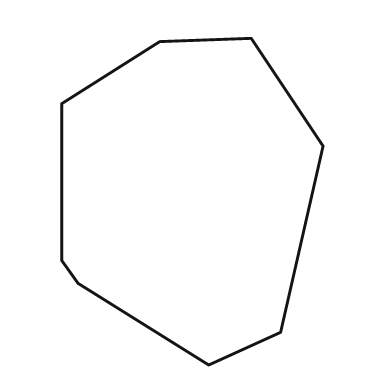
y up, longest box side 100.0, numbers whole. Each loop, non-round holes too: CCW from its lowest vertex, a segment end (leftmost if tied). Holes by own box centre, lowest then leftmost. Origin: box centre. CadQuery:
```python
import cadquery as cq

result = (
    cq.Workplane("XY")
    .moveTo(5.0, -50.0)
    .lineTo(27.0, -40.0)
    .lineTo(40.0, 17.0)
    .lineTo(18.0, 50.0)
    .lineTo(-10.0, 49.0)
    .lineTo(-40.0, 30.0)
    .lineTo(-40.0, -18.0)
    .lineTo(-35.0, -25.0)
    .close()
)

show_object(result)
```